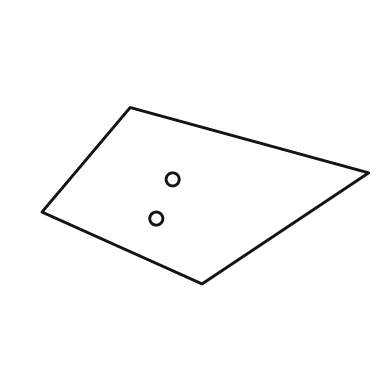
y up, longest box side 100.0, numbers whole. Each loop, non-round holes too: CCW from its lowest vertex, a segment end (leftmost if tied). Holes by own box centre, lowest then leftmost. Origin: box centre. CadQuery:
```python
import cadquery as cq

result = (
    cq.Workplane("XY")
    .moveTo(-1.0, -27.0)
    .lineTo(50.0, 7.0)
    .lineTo(-23.0, 27.0)
    .lineTo(-50.0, -5.0)
    .close()
    .moveTo(-15.0, -7.0)
    .circle(2.0)
    .moveTo(-10.0, 5.0)
    .circle(2.0)
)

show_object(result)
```